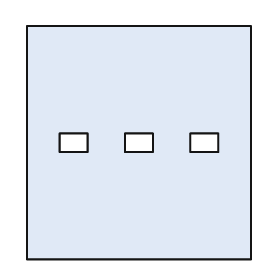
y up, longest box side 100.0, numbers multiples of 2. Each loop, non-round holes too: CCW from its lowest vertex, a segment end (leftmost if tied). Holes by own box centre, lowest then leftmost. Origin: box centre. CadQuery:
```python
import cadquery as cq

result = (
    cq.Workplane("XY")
    .moveTo(-48.0, -50.0)
    .lineTo(48.0, -50.0)
    .lineTo(48.0, 50.0)
    .lineTo(-48.0, 50.0)
    .close()
    .moveTo(-34.0, -4.0)
    .lineTo(-22.0, -4.0)
    .lineTo(-22.0, 4.0)
    .lineTo(-34.0, 4.0)
    .close()
    .moveTo(-6.0, -4.0)
    .lineTo(6.0, -4.0)
    .lineTo(6.0, 4.0)
    .lineTo(-6.0, 4.0)
    .close()
    .moveTo(22.0, -4.0)
    .lineTo(34.0, -4.0)
    .lineTo(34.0, 4.0)
    .lineTo(22.0, 4.0)
    .close()
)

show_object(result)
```